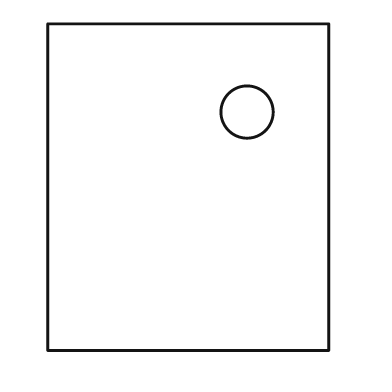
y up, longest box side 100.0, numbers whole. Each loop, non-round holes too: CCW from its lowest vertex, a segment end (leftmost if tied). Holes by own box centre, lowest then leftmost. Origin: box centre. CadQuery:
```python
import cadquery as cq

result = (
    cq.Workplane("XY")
    .moveTo(-43.0, -50.0)
    .lineTo(43.0, -50.0)
    .lineTo(43.0, 50.0)
    .lineTo(-43.0, 50.0)
    .close()
    .moveTo(18.0, 23.0)
    .circle(8.0)
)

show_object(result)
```